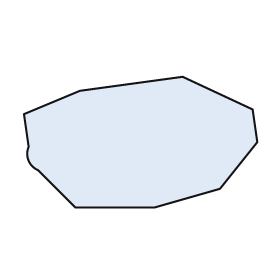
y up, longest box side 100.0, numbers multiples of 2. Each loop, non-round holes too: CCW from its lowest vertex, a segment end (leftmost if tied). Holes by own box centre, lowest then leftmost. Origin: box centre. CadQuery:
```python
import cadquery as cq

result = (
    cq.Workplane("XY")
    .moveTo(-28.0, -28.0)
    .lineTo(6.0, -28.0)
    .lineTo(34.0, -20.0)
    .lineTo(50.0, 0.0)
    .lineTo(48.0, 14.0)
    .lineTo(18.0, 28.0)
    .lineTo(-26.0, 22.0)
    .lineTo(-50.0, 12.0)
    .lineTo(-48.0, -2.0)
    .threePointArc((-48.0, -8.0), (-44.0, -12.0))
    .close()
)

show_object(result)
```